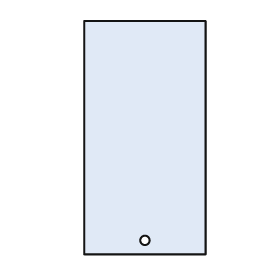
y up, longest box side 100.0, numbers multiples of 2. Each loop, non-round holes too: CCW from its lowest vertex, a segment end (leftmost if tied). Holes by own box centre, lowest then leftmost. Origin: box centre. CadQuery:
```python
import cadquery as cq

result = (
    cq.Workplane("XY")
    .moveTo(-26.0, -50.0)
    .lineTo(26.0, -50.0)
    .lineTo(26.0, 50.0)
    .lineTo(-26.0, 50.0)
    .close()
    .moveTo(0.0, -44.0)
    .circle(2.0)
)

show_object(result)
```